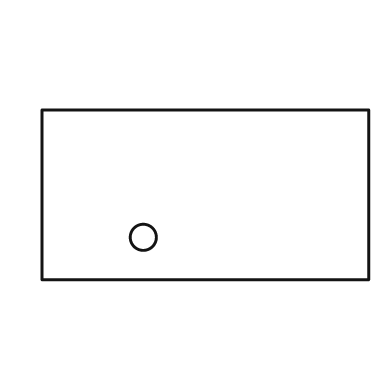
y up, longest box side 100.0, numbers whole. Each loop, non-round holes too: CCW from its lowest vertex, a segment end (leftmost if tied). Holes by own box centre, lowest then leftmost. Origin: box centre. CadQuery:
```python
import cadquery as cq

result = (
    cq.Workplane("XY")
    .moveTo(-50.0, -26.0)
    .lineTo(50.0, -26.0)
    .lineTo(50.0, 26.0)
    .lineTo(-50.0, 26.0)
    .close()
    .moveTo(-19.0, -13.0)
    .circle(4.0)
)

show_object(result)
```